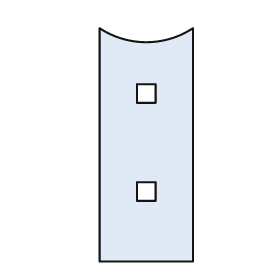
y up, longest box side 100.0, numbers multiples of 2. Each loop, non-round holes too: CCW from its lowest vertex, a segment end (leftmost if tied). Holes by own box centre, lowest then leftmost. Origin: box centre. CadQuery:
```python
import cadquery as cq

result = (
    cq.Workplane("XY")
    .moveTo(-20.0, -50.0)
    .lineTo(20.0, -50.0)
    .lineTo(20.0, 50.0)
    .threePointArc((0.0, 44.0), (-20.0, 50.0))
    .close()
    .moveTo(-4.0, -24.0)
    .lineTo(4.0, -24.0)
    .lineTo(4.0, -16.0)
    .lineTo(-4.0, -16.0)
    .close()
    .moveTo(-4.0, 18.0)
    .lineTo(4.0, 18.0)
    .lineTo(4.0, 26.0)
    .lineTo(-4.0, 26.0)
    .close()
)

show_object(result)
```